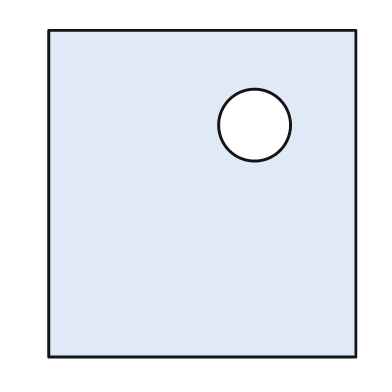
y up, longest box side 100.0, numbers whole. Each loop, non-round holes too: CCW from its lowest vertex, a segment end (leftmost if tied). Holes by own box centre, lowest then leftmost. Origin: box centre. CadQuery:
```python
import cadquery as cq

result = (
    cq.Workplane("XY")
    .moveTo(-47.0, -50.0)
    .lineTo(47.0, -50.0)
    .lineTo(47.0, 50.0)
    .lineTo(-47.0, 50.0)
    .close()
    .moveTo(16.0, 21.0)
    .circle(11.0)
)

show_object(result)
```